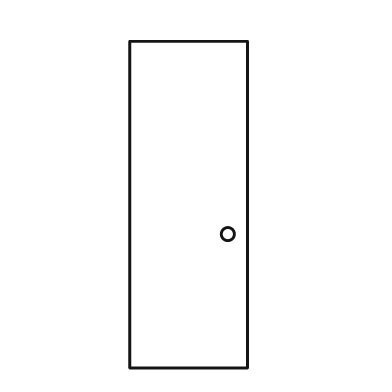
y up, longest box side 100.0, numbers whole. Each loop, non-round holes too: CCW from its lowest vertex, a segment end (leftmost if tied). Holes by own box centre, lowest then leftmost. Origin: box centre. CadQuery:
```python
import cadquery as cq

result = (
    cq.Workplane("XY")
    .moveTo(-18.0, -50.0)
    .lineTo(18.0, -50.0)
    .lineTo(18.0, 50.0)
    .lineTo(-18.0, 50.0)
    .close()
    .moveTo(12.0, -9.0)
    .circle(2.0)
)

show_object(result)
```